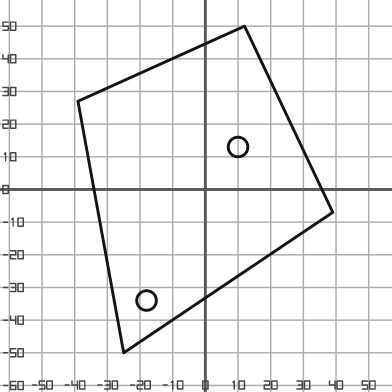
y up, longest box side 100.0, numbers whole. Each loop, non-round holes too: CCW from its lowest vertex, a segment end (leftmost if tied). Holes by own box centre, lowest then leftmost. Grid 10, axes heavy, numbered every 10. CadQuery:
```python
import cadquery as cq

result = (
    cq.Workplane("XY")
    .moveTo(-25.0, -50.0)
    .lineTo(39.0, -7.0)
    .lineTo(12.0, 50.0)
    .lineTo(-39.0, 27.0)
    .close()
    .moveTo(-18.0, -34.0)
    .circle(3.0)
    .moveTo(10.0, 13.0)
    .circle(3.0)
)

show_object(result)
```